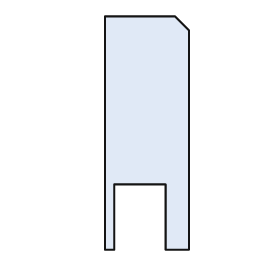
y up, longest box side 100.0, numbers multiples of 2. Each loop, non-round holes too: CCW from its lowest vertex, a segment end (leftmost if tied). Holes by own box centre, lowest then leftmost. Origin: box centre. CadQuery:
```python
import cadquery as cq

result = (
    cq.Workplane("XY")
    .moveTo(-18.0, -50.0)
    .lineTo(-14.0, -50.0)
    .lineTo(-14.0, -22.0)
    .lineTo(8.0, -22.0)
    .lineTo(8.0, -50.0)
    .lineTo(18.0, -50.0)
    .lineTo(18.0, 44.0)
    .lineTo(12.0, 50.0)
    .lineTo(-18.0, 50.0)
    .close()
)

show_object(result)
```